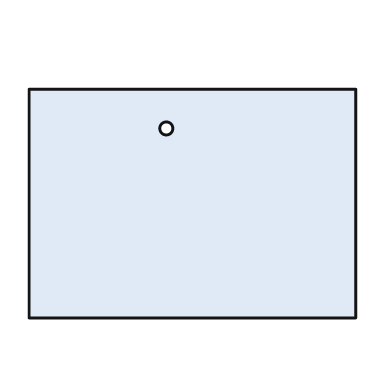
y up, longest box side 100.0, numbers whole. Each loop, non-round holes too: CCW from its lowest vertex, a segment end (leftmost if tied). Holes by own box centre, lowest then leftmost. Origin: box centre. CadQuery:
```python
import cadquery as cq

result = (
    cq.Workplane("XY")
    .moveTo(-50.0, -35.0)
    .lineTo(50.0, -35.0)
    .lineTo(50.0, 35.0)
    .lineTo(-50.0, 35.0)
    .close()
    .moveTo(-8.0, 23.0)
    .circle(2.0)
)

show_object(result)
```